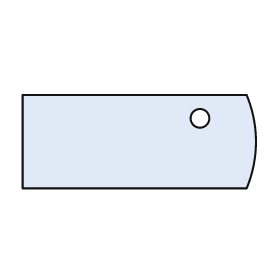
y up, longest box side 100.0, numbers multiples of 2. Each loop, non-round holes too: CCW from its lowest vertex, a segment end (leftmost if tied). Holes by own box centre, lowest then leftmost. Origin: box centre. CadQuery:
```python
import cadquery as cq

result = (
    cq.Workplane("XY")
    .moveTo(-50.0, -20.0)
    .lineTo(46.0, -20.0)
    .threePointArc((50.0, 0.0), (46.0, 20.0))
    .lineTo(-50.0, 20.0)
    .close()
    .moveTo(26.0, 10.0)
    .circle(4.0)
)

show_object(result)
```